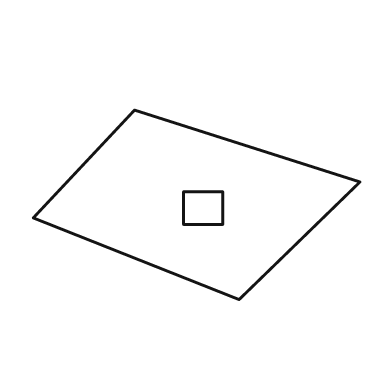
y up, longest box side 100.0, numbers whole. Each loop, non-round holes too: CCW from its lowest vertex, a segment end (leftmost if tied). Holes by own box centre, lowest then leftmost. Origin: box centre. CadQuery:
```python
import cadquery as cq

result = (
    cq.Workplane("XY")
    .moveTo(13.0, -29.0)
    .lineTo(50.0, 7.0)
    .lineTo(-19.0, 29.0)
    .lineTo(-50.0, -4.0)
    .close()
    .moveTo(-4.0, -6.0)
    .lineTo(8.0, -6.0)
    .lineTo(8.0, 4.0)
    .lineTo(-4.0, 4.0)
    .close()
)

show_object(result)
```